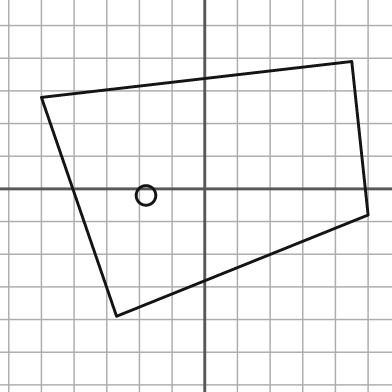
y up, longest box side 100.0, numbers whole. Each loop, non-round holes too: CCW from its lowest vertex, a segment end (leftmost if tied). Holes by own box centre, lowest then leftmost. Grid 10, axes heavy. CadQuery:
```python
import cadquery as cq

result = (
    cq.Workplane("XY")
    .moveTo(-27.0, -39.0)
    .lineTo(50.0, -8.0)
    .lineTo(45.0, 39.0)
    .lineTo(-50.0, 28.0)
    .close()
    .moveTo(-18.0, -2.0)
    .circle(3.0)
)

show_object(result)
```